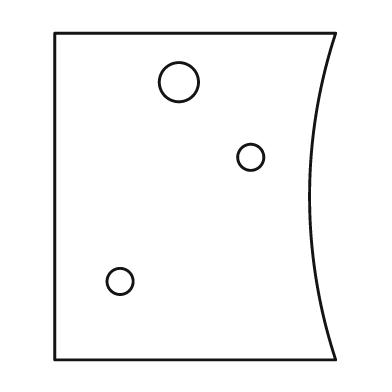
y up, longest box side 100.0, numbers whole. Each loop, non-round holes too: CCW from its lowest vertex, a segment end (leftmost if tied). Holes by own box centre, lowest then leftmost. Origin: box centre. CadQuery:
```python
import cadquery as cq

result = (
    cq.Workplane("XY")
    .moveTo(-43.0, -50.0)
    .lineTo(43.0, -50.0)
    .threePointArc((35.0, 0.0), (43.0, 50.0))
    .lineTo(-43.0, 50.0)
    .close()
    .moveTo(-23.0, -26.0)
    .circle(4.0)
    .moveTo(17.0, 12.0)
    .circle(4.0)
    .moveTo(-5.0, 35.0)
    .circle(6.0)
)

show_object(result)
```